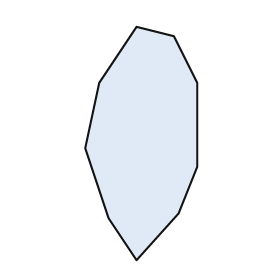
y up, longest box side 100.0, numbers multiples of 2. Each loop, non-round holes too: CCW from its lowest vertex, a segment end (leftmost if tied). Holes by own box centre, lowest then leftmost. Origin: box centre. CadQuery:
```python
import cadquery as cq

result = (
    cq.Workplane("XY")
    .moveTo(-2.0, -50.0)
    .lineTo(16.0, -30.0)
    .lineTo(24.0, -10.0)
    .lineTo(24.0, 26.0)
    .lineTo(14.0, 46.0)
    .lineTo(-2.0, 50.0)
    .lineTo(-18.0, 26.0)
    .lineTo(-24.0, -2.0)
    .lineTo(-14.0, -32.0)
    .close()
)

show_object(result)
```